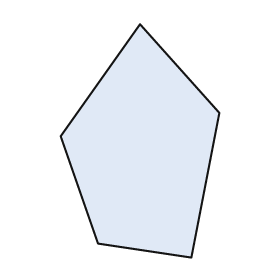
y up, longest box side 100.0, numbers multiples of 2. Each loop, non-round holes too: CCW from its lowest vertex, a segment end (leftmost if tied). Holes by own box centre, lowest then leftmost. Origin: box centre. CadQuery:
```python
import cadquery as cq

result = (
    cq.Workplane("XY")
    .moveTo(22.0, -50.0)
    .lineTo(34.0, 12.0)
    .lineTo(0.0, 50.0)
    .lineTo(-34.0, 2.0)
    .lineTo(-18.0, -44.0)
    .close()
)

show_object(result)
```